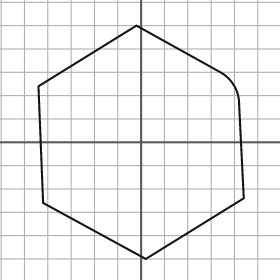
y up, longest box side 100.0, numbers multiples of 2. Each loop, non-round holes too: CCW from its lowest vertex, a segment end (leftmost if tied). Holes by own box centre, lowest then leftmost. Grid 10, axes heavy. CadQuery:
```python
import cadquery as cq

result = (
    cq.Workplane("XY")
    .moveTo(2.0, -50.0)
    .lineTo(44.0, -24.0)
    .lineTo(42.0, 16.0)
    .threePointArc((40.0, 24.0), (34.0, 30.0))
    .lineTo(-2.0, 50.0)
    .lineTo(-44.0, 24.0)
    .lineTo(-42.0, -26.0)
    .close()
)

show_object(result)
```